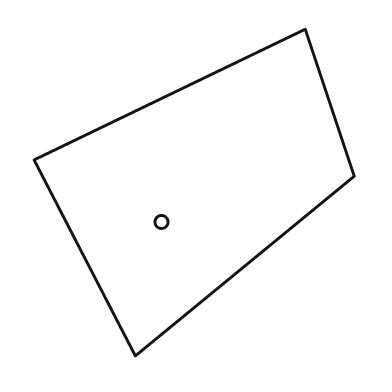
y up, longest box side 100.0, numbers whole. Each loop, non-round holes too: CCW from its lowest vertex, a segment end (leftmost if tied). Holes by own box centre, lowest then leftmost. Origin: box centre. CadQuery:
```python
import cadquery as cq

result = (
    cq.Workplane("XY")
    .moveTo(-18.0, -50.0)
    .lineTo(49.0, 5.0)
    .lineTo(34.0, 50.0)
    .lineTo(-49.0, 10.0)
    .close()
    .moveTo(-10.0, -9.0)
    .circle(2.0)
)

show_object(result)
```